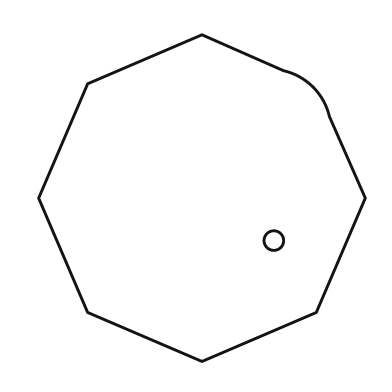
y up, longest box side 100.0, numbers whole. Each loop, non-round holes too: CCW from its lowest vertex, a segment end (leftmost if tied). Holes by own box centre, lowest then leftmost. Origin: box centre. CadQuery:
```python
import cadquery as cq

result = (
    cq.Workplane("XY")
    .moveTo(0.0, -50.0)
    .lineTo(35.0, -35.0)
    .lineTo(50.0, 0.0)
    .lineTo(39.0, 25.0)
    .threePointArc((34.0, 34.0), (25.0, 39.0))
    .lineTo(0.0, 50.0)
    .lineTo(-35.0, 35.0)
    .lineTo(-50.0, 0.0)
    .lineTo(-35.0, -35.0)
    .close()
    .moveTo(22.0, -13.0)
    .circle(3.0)
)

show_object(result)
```